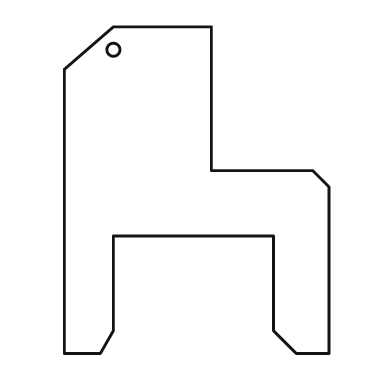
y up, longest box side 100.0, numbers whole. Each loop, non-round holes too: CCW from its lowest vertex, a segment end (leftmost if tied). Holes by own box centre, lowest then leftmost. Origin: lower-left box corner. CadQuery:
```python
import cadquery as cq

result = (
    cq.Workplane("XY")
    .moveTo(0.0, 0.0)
    .lineTo(11.0, 0.0)
    .lineTo(15.0, 7.0)
    .lineTo(15.0, 36.0)
    .lineTo(64.0, 36.0)
    .lineTo(64.0, 7.0)
    .lineTo(71.0, 0.0)
    .lineTo(81.0, 0.0)
    .lineTo(81.0, 51.0)
    .lineTo(76.0, 56.0)
    .lineTo(45.0, 56.0)
    .lineTo(45.0, 100.0)
    .lineTo(15.0, 100.0)
    .lineTo(0.0, 87.0)
    .close()
    .moveTo(15.0, 93.0)
    .circle(2.0)
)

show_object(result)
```